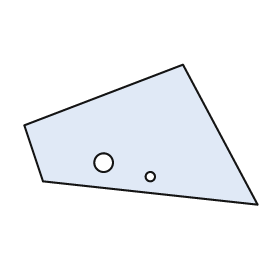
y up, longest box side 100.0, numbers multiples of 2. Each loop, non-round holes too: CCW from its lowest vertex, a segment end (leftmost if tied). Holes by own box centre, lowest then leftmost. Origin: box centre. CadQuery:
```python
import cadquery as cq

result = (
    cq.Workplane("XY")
    .moveTo(50.0, -30.0)
    .lineTo(18.0, 30.0)
    .lineTo(-50.0, 4.0)
    .lineTo(-42.0, -20.0)
    .close()
    .moveTo(4.0, -18.0)
    .circle(2.0)
    .moveTo(-16.0, -12.0)
    .circle(4.0)
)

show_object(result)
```